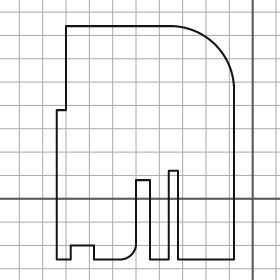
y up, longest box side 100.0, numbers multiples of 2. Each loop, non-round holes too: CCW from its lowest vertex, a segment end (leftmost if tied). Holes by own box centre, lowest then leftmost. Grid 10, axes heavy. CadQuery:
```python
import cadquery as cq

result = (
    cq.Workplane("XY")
    .moveTo(-84.0, -26.0)
    .lineTo(-78.0, -26.0)
    .lineTo(-78.0, -20.0)
    .lineTo(-68.0, -20.0)
    .lineTo(-68.0, -26.0)
    .lineTo(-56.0, -26.0)
    .threePointArc((-52.0, -24.0), (-50.0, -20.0))
    .lineTo(-50.0, 8.0)
    .lineTo(-44.0, 8.0)
    .lineTo(-44.0, -26.0)
    .lineTo(-36.0, -26.0)
    .lineTo(-36.0, 12.0)
    .lineTo(-32.0, 12.0)
    .lineTo(-32.0, -26.0)
    .lineTo(-8.0, -26.0)
    .lineTo(-8.0, 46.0)
    .threePointArc((-16.0, 66.0), (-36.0, 74.0))
    .lineTo(-80.0, 74.0)
    .lineTo(-80.0, 38.0)
    .lineTo(-84.0, 38.0)
    .close()
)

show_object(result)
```